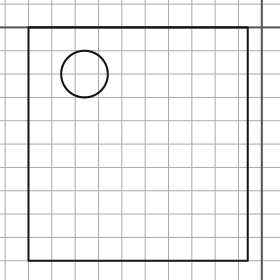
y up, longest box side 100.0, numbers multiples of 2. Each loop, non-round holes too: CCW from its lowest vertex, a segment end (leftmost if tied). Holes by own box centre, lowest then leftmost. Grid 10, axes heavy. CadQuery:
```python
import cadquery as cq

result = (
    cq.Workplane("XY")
    .moveTo(-100.0, -100.0)
    .lineTo(-6.0, -100.0)
    .lineTo(-6.0, 0.0)
    .lineTo(-100.0, 0.0)
    .close()
    .moveTo(-76.0, -20.0)
    .circle(10.0)
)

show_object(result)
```